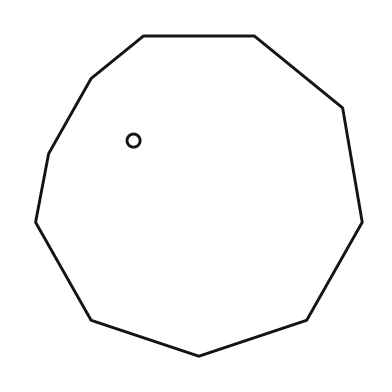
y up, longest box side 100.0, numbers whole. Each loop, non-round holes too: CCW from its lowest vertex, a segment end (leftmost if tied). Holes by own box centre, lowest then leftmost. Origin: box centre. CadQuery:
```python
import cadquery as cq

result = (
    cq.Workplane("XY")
    .moveTo(0.0, -49.0)
    .lineTo(33.0, -38.0)
    .lineTo(50.0, -8.0)
    .lineTo(44.0, 27.0)
    .lineTo(17.0, 49.0)
    .lineTo(-17.0, 49.0)
    .lineTo(-33.0, 36.0)
    .lineTo(-46.0, 13.0)
    .lineTo(-50.0, -8.0)
    .lineTo(-33.0, -38.0)
    .close()
    .moveTo(-20.0, 17.0)
    .circle(2.0)
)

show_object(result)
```